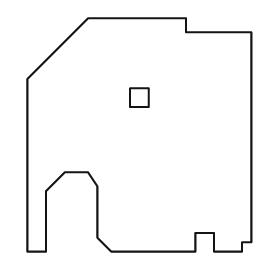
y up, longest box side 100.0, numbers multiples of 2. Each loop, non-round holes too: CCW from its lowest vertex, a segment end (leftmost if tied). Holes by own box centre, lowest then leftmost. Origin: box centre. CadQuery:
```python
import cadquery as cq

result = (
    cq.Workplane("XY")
    .moveTo(-48.0, -50.0)
    .lineTo(-40.0, -50.0)
    .lineTo(-40.0, -24.0)
    .lineTo(-32.0, -16.0)
    .lineTo(-22.0, -16.0)
    .lineTo(-18.0, -22.0)
    .lineTo(-18.0, -44.0)
    .lineTo(-12.0, -50.0)
    .lineTo(24.0, -50.0)
    .lineTo(24.0, -42.0)
    .lineTo(32.0, -42.0)
    .lineTo(32.0, -50.0)
    .lineTo(44.0, -50.0)
    .lineTo(44.0, -46.0)
    .lineTo(48.0, -46.0)
    .lineTo(48.0, 44.0)
    .lineTo(20.0, 44.0)
    .lineTo(20.0, 50.0)
    .lineTo(-22.0, 50.0)
    .lineTo(-48.0, 24.0)
    .close()
    .moveTo(-4.0, 12.0)
    .lineTo(4.0, 12.0)
    .lineTo(4.0, 20.0)
    .lineTo(-4.0, 20.0)
    .close()
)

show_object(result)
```